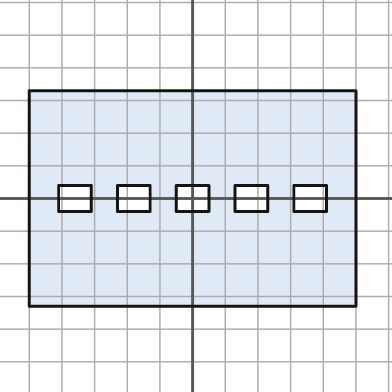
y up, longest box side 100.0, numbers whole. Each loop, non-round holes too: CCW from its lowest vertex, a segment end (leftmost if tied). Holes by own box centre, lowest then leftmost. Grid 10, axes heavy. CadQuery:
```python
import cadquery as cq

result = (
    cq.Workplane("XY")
    .moveTo(-50.0, -33.0)
    .lineTo(50.0, -33.0)
    .lineTo(50.0, 33.0)
    .lineTo(-50.0, 33.0)
    .close()
    .moveTo(-41.0, -4.0)
    .lineTo(-31.0, -4.0)
    .lineTo(-31.0, 4.0)
    .lineTo(-41.0, 4.0)
    .close()
    .moveTo(-23.0, -4.0)
    .lineTo(-13.0, -4.0)
    .lineTo(-13.0, 4.0)
    .lineTo(-23.0, 4.0)
    .close()
    .moveTo(-5.0, -4.0)
    .lineTo(5.0, -4.0)
    .lineTo(5.0, 4.0)
    .lineTo(-5.0, 4.0)
    .close()
    .moveTo(13.0, -4.0)
    .lineTo(23.0, -4.0)
    .lineTo(23.0, 4.0)
    .lineTo(13.0, 4.0)
    .close()
    .moveTo(31.0, -4.0)
    .lineTo(41.0, -4.0)
    .lineTo(41.0, 4.0)
    .lineTo(31.0, 4.0)
    .close()
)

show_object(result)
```